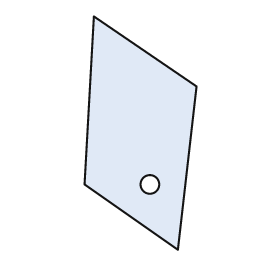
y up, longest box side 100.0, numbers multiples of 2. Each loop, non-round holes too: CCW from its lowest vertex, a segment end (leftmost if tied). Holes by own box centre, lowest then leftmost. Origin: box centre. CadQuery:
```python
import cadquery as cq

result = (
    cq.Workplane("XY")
    .moveTo(16.0, -50.0)
    .lineTo(24.0, 20.0)
    .lineTo(-20.0, 50.0)
    .lineTo(-24.0, -22.0)
    .close()
    .moveTo(4.0, -22.0)
    .circle(4.0)
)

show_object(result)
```